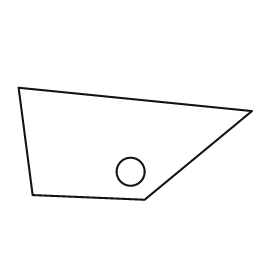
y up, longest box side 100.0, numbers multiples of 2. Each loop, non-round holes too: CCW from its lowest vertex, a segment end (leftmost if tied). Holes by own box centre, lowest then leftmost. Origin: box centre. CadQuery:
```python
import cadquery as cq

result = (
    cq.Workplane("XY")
    .moveTo(4.0, -24.0)
    .lineTo(50.0, 14.0)
    .lineTo(-50.0, 24.0)
    .lineTo(-44.0, -22.0)
    .close()
    .moveTo(-2.0, -12.0)
    .circle(6.0)
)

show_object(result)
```